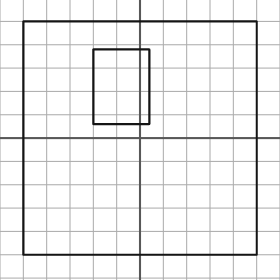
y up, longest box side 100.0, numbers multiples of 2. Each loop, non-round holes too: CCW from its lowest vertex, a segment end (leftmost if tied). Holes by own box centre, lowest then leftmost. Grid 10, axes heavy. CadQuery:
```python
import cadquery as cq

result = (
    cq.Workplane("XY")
    .moveTo(-50.0, -50.0)
    .lineTo(50.0, -50.0)
    .lineTo(50.0, 50.0)
    .lineTo(-50.0, 50.0)
    .close()
    .moveTo(-20.0, 6.0)
    .lineTo(4.0, 6.0)
    .lineTo(4.0, 38.0)
    .lineTo(-20.0, 38.0)
    .close()
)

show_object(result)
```